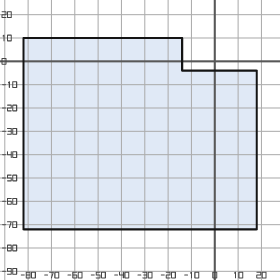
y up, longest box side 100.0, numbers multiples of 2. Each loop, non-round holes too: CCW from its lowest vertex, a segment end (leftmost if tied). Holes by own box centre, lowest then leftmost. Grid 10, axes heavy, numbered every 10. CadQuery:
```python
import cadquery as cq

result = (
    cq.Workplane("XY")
    .moveTo(-82.0, -72.0)
    .lineTo(18.0, -72.0)
    .lineTo(18.0, -4.0)
    .lineTo(-14.0, -4.0)
    .lineTo(-14.0, 10.0)
    .lineTo(-82.0, 10.0)
    .close()
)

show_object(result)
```